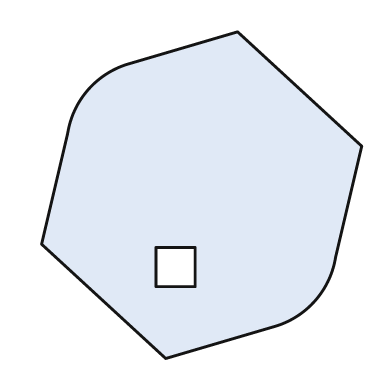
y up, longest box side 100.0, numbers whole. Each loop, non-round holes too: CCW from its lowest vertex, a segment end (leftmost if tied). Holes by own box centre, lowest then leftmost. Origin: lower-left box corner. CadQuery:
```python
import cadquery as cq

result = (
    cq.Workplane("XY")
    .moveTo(38.0, 0.0)
    .lineTo(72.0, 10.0)
    .threePointArc((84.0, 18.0), (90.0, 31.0))
    .lineTo(98.0, 65.0)
    .lineTo(60.0, 100.0)
    .lineTo(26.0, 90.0)
    .threePointArc((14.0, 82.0), (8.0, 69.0))
    .lineTo(0.0, 35.0)
    .close()
    .moveTo(35.0, 22.0)
    .lineTo(47.0, 22.0)
    .lineTo(47.0, 34.0)
    .lineTo(35.0, 34.0)
    .close()
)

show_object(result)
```